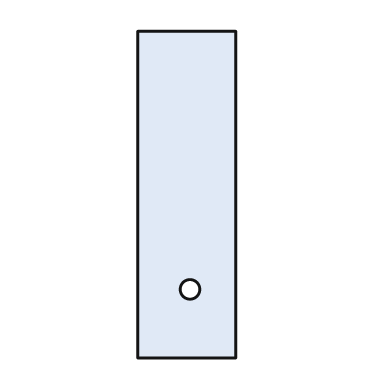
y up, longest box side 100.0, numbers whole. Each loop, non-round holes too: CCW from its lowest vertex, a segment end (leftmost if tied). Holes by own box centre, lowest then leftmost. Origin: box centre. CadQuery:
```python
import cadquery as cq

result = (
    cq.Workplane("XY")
    .moveTo(-15.0, -50.0)
    .lineTo(15.0, -50.0)
    .lineTo(15.0, 50.0)
    .lineTo(-15.0, 50.0)
    .close()
    .moveTo(1.0, -29.0)
    .circle(3.0)
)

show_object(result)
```